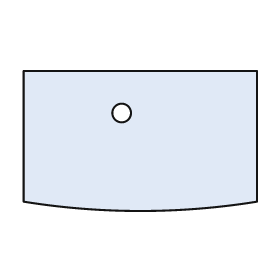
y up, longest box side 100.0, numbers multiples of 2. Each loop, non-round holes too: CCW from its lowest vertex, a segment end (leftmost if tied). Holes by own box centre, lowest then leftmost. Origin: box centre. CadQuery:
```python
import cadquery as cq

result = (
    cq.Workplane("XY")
    .moveTo(-50.0, -26.0)
    .threePointArc((0.0, -30.0), (50.0, -26.0))
    .lineTo(50.0, 30.0)
    .lineTo(-50.0, 30.0)
    .close()
    .moveTo(-8.0, 12.0)
    .circle(4.0)
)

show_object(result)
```